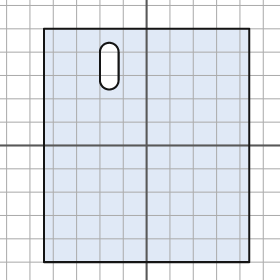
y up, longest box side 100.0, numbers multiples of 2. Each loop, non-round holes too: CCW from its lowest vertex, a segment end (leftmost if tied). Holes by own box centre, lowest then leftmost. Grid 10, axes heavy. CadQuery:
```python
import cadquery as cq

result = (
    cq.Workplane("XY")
    .moveTo(-44.0, -50.0)
    .lineTo(44.0, -50.0)
    .lineTo(44.0, 50.0)
    .lineTo(-44.0, 50.0)
    .close()
    .moveTo(-20.0, 28.0)
    .threePointArc((-16.0, 24.0), (-12.0, 28.0))
    .lineTo(-12.0, 40.0)
    .threePointArc((-16.0, 44.0), (-20.0, 40.0))
    .close()
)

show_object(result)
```